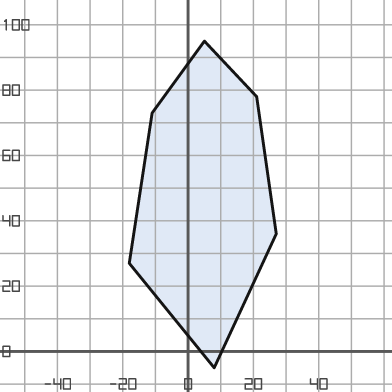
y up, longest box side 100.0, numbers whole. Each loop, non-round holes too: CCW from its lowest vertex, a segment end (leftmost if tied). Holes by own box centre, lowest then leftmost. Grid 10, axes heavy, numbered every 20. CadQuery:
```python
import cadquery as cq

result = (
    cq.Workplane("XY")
    .moveTo(8.0, -5.0)
    .lineTo(27.0, 36.0)
    .lineTo(21.0, 78.0)
    .lineTo(5.0, 95.0)
    .lineTo(-11.0, 73.0)
    .lineTo(-18.0, 27.0)
    .close()
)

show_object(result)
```